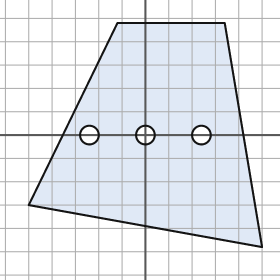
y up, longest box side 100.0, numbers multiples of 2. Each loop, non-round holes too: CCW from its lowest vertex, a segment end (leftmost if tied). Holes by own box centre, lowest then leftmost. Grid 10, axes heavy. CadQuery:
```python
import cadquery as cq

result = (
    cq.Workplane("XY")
    .moveTo(50.0, -48.0)
    .lineTo(34.0, 48.0)
    .lineTo(-12.0, 48.0)
    .lineTo(-50.0, -30.0)
    .close()
    .moveTo(-24.0, 0.0)
    .circle(4.0)
    .moveTo(0.0, 0.0)
    .circle(4.0)
    .moveTo(24.0, 0.0)
    .circle(4.0)
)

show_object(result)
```